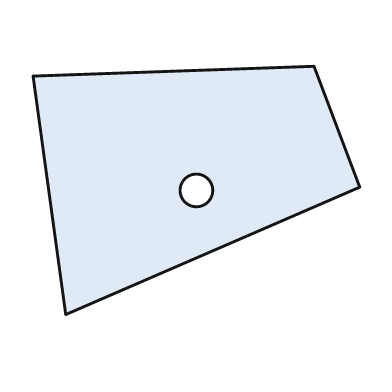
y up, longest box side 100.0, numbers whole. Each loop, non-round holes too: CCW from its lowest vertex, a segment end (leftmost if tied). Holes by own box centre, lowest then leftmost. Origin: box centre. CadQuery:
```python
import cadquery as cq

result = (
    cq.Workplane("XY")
    .moveTo(-40.0, -38.0)
    .lineTo(50.0, 1.0)
    .lineTo(36.0, 38.0)
    .lineTo(-50.0, 35.0)
    .close()
    .moveTo(0.0, 0.0)
    .circle(5.0)
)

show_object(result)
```